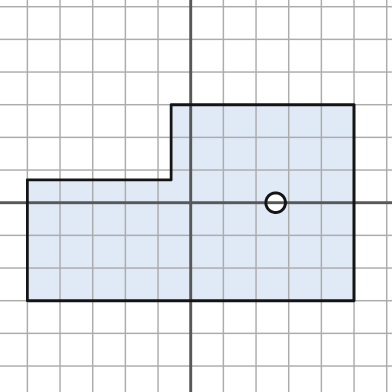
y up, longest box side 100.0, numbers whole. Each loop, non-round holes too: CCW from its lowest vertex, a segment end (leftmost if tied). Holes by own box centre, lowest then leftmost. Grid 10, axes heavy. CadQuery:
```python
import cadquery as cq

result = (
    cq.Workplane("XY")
    .moveTo(-50.0, -30.0)
    .lineTo(50.0, -30.0)
    .lineTo(50.0, 30.0)
    .lineTo(-6.0, 30.0)
    .lineTo(-6.0, 7.0)
    .lineTo(-50.0, 7.0)
    .close()
    .moveTo(26.0, 0.0)
    .circle(3.0)
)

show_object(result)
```